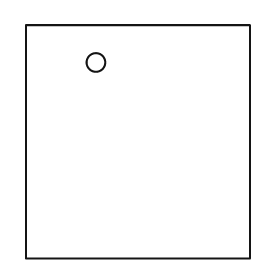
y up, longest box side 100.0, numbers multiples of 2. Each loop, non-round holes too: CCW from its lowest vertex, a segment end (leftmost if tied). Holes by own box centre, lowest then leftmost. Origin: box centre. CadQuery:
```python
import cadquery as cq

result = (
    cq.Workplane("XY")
    .moveTo(-48.0, -50.0)
    .lineTo(48.0, -50.0)
    .lineTo(48.0, 50.0)
    .lineTo(-48.0, 50.0)
    .close()
    .moveTo(-18.0, 34.0)
    .circle(4.0)
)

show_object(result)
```